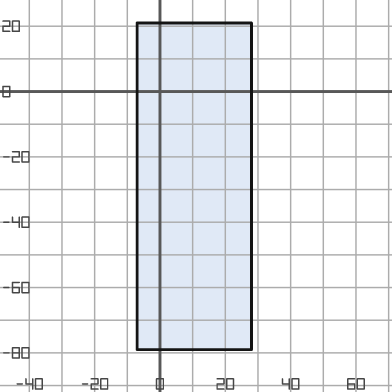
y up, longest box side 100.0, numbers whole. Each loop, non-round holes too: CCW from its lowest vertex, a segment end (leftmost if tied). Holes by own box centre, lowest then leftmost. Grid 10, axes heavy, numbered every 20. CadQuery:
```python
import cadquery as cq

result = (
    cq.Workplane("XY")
    .moveTo(-7.0, -79.0)
    .lineTo(28.0, -79.0)
    .lineTo(28.0, 21.0)
    .lineTo(-7.0, 21.0)
    .close()
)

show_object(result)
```